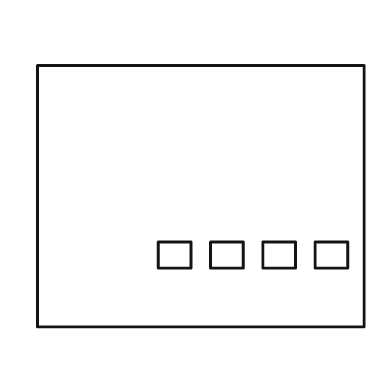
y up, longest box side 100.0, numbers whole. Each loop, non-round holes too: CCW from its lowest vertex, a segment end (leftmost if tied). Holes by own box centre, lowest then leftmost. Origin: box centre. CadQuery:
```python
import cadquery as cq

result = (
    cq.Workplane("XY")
    .moveTo(-50.0, -40.0)
    .lineTo(50.0, -40.0)
    .lineTo(50.0, 40.0)
    .lineTo(-50.0, 40.0)
    .close()
    .moveTo(-13.0, -22.0)
    .lineTo(-3.0, -22.0)
    .lineTo(-3.0, -14.0)
    .lineTo(-13.0, -14.0)
    .close()
    .moveTo(3.0, -22.0)
    .lineTo(13.0, -22.0)
    .lineTo(13.0, -14.0)
    .lineTo(3.0, -14.0)
    .close()
    .moveTo(19.0, -22.0)
    .lineTo(29.0, -22.0)
    .lineTo(29.0, -14.0)
    .lineTo(19.0, -14.0)
    .close()
    .moveTo(35.0, -22.0)
    .lineTo(45.0, -22.0)
    .lineTo(45.0, -14.0)
    .lineTo(35.0, -14.0)
    .close()
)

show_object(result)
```